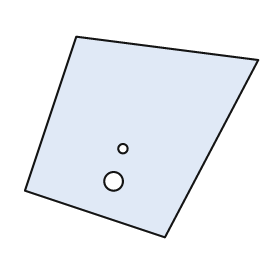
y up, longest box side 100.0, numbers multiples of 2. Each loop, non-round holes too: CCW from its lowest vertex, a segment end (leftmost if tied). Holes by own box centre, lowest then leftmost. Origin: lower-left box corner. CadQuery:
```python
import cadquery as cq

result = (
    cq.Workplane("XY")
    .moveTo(60.0, 0.0)
    .lineTo(100.0, 76.0)
    .lineTo(22.0, 86.0)
    .lineTo(0.0, 20.0)
    .close()
    .moveTo(38.0, 24.0)
    .circle(4.0)
    .moveTo(42.0, 38.0)
    .circle(2.0)
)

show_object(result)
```